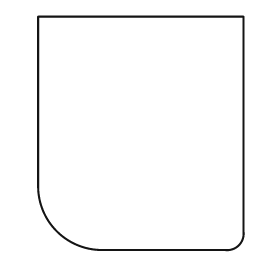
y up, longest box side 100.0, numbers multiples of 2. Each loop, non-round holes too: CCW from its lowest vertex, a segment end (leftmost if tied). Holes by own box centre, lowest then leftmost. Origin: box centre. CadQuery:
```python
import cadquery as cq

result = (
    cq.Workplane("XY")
    .moveTo(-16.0, -50.0)
    .lineTo(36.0, -50.0)
    .threePointArc((42.0, -48.0), (44.0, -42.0))
    .lineTo(44.0, 50.0)
    .lineTo(-44.0, 50.0)
    .lineTo(-44.0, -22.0)
    .threePointArc((-36.0, -42.0), (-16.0, -50.0))
    .close()
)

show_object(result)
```